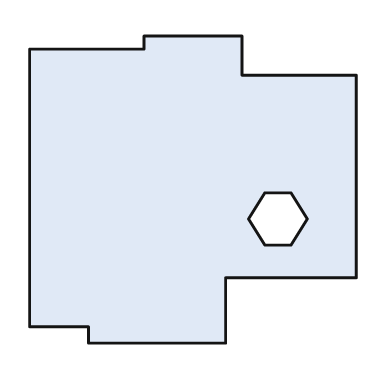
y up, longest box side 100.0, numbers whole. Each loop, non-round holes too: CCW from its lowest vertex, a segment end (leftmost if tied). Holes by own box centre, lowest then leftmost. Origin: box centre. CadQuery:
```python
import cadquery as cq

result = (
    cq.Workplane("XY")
    .moveTo(-32.0, -47.0)
    .lineTo(10.0, -47.0)
    .lineTo(10.0, -27.0)
    .lineTo(50.0, -27.0)
    .lineTo(50.0, 35.0)
    .lineTo(15.0, 35.0)
    .lineTo(15.0, 47.0)
    .lineTo(-15.0, 47.0)
    .lineTo(-15.0, 43.0)
    .lineTo(-50.0, 43.0)
    .lineTo(-50.0, -42.0)
    .lineTo(-32.0, -42.0)
    .close()
    .moveTo(22.0, -17.0)
    .lineTo(30.0, -17.0)
    .lineTo(35.0, -9.0)
    .lineTo(30.0, -1.0)
    .lineTo(22.0, -1.0)
    .lineTo(17.0, -9.0)
    .close()
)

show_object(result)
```